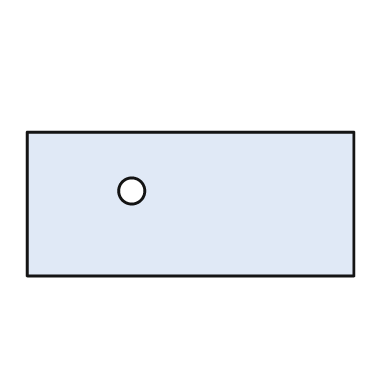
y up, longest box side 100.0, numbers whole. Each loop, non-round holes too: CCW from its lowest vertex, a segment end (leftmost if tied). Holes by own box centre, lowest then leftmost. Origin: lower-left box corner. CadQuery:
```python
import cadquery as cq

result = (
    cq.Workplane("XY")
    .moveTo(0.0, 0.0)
    .lineTo(100.0, 0.0)
    .lineTo(100.0, 44.0)
    .lineTo(0.0, 44.0)
    .close()
    .moveTo(32.0, 26.0)
    .circle(4.0)
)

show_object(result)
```